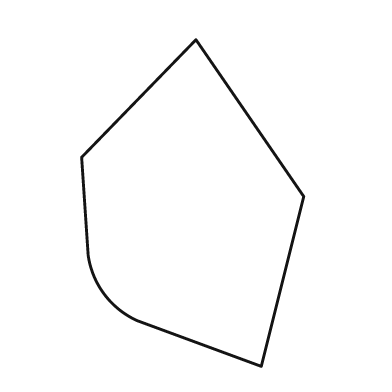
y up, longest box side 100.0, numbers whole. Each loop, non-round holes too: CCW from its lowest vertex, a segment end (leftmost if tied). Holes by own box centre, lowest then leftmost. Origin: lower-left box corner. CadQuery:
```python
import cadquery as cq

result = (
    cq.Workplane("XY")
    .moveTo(55.0, 0.0)
    .lineTo(68.0, 52.0)
    .lineTo(35.0, 100.0)
    .lineTo(0.0, 64.0)
    .lineTo(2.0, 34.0)
    .threePointArc((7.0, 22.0), (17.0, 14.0))
    .close()
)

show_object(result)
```